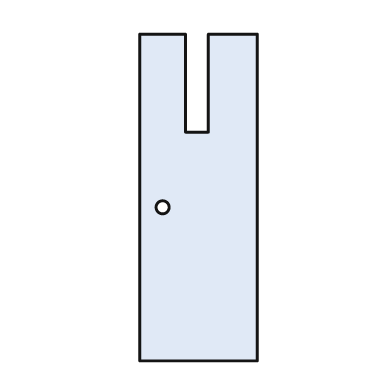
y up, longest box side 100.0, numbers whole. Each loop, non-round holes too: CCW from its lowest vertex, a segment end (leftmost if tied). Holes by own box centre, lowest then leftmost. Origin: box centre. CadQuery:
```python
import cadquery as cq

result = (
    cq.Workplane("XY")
    .moveTo(-18.0, -50.0)
    .lineTo(18.0, -50.0)
    .lineTo(18.0, 50.0)
    .lineTo(3.0, 50.0)
    .lineTo(3.0, 20.0)
    .lineTo(-4.0, 20.0)
    .lineTo(-4.0, 50.0)
    .lineTo(-18.0, 50.0)
    .close()
    .moveTo(-11.0, -3.0)
    .circle(2.0)
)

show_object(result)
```